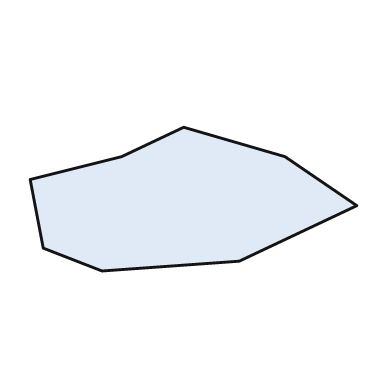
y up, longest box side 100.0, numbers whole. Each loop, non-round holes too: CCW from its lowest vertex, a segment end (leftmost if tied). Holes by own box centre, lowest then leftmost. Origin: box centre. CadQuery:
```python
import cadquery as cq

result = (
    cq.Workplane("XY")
    .moveTo(-28.0, -22.0)
    .lineTo(14.0, -19.0)
    .lineTo(50.0, -2.0)
    .lineTo(28.0, 13.0)
    .lineTo(-3.0, 22.0)
    .lineTo(-22.0, 13.0)
    .lineTo(-50.0, 6.0)
    .lineTo(-46.0, -15.0)
    .close()
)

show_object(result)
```